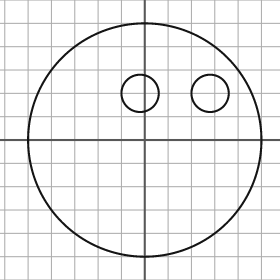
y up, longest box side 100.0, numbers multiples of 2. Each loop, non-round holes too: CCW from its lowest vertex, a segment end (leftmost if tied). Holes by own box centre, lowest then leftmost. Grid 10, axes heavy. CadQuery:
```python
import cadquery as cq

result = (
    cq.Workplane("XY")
    .moveTo(0.0, 0.0)
    .circle(50.0)
    .moveTo(-2.0, 20.0)
    .circle(8.0)
    .moveTo(28.0, 20.0)
    .circle(8.0)
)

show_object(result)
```